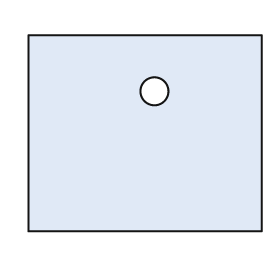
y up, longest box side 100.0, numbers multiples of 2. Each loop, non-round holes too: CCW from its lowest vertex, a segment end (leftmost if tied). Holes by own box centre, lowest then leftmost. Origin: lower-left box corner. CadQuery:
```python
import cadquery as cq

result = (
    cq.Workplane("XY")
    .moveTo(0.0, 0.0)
    .lineTo(100.0, 0.0)
    .lineTo(100.0, 84.0)
    .lineTo(0.0, 84.0)
    .close()
    .moveTo(54.0, 60.0)
    .circle(6.0)
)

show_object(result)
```